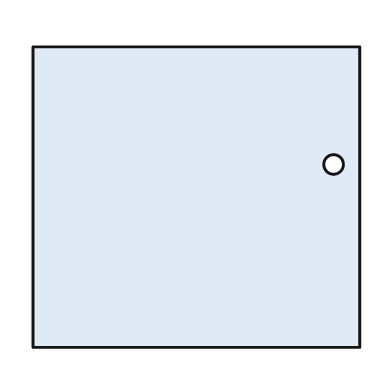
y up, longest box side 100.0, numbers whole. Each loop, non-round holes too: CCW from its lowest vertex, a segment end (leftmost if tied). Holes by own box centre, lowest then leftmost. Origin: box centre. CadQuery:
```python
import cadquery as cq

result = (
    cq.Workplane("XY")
    .moveTo(-50.0, -46.0)
    .lineTo(50.0, -46.0)
    .lineTo(50.0, 46.0)
    .lineTo(-50.0, 46.0)
    .close()
    .moveTo(42.0, 10.0)
    .circle(3.0)
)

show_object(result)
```